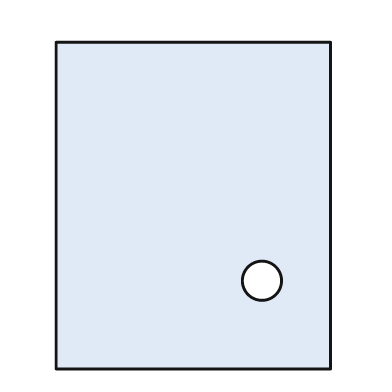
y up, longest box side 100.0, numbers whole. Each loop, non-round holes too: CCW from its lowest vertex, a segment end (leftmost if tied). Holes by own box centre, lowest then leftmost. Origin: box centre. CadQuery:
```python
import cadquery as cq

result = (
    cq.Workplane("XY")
    .moveTo(-42.0, -50.0)
    .lineTo(42.0, -50.0)
    .lineTo(42.0, 50.0)
    .lineTo(-42.0, 50.0)
    .close()
    .moveTo(21.0, -23.0)
    .circle(6.0)
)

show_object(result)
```